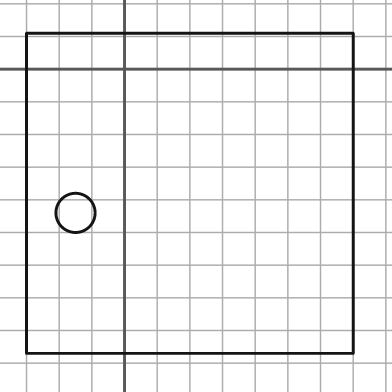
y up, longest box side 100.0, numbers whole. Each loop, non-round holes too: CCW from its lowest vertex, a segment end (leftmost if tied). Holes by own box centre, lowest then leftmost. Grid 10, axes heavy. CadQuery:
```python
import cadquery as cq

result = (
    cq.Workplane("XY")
    .moveTo(-30.0, -87.0)
    .lineTo(70.0, -87.0)
    .lineTo(70.0, 11.0)
    .lineTo(-30.0, 11.0)
    .close()
    .moveTo(-15.0, -44.0)
    .circle(6.0)
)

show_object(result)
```